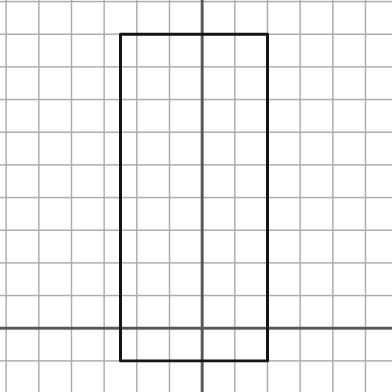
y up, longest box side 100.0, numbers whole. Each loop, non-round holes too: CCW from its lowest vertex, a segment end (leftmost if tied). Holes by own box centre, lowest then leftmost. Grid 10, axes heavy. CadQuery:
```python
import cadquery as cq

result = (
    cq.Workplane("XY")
    .moveTo(-25.0, -10.0)
    .lineTo(20.0, -10.0)
    .lineTo(20.0, 90.0)
    .lineTo(-25.0, 90.0)
    .close()
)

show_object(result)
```